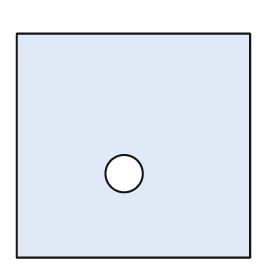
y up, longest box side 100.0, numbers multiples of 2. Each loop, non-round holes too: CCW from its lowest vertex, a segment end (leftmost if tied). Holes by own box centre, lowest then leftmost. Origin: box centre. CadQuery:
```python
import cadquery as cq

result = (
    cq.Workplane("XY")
    .moveTo(-50.0, -48.0)
    .lineTo(50.0, -48.0)
    .lineTo(50.0, 48.0)
    .lineTo(-50.0, 48.0)
    .close()
    .moveTo(-4.0, -12.0)
    .circle(8.0)
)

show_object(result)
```